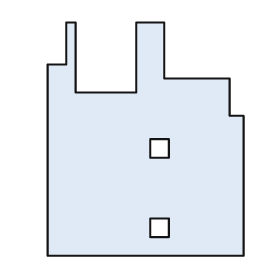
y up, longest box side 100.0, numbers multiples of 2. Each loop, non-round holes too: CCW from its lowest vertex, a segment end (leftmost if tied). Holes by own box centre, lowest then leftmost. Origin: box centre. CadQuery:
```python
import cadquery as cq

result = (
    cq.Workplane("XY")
    .moveTo(-42.0, -50.0)
    .lineTo(42.0, -50.0)
    .lineTo(42.0, 10.0)
    .lineTo(36.0, 10.0)
    .lineTo(36.0, 26.0)
    .lineTo(8.0, 26.0)
    .lineTo(8.0, 50.0)
    .lineTo(-4.0, 50.0)
    .lineTo(-4.0, 20.0)
    .lineTo(-30.0, 20.0)
    .lineTo(-30.0, 50.0)
    .lineTo(-34.0, 50.0)
    .lineTo(-34.0, 32.0)
    .lineTo(-42.0, 32.0)
    .close()
    .moveTo(2.0, -42.0)
    .lineTo(10.0, -42.0)
    .lineTo(10.0, -34.0)
    .lineTo(2.0, -34.0)
    .close()
    .moveTo(2.0, -8.0)
    .lineTo(10.0, -8.0)
    .lineTo(10.0, 0.0)
    .lineTo(2.0, 0.0)
    .close()
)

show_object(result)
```